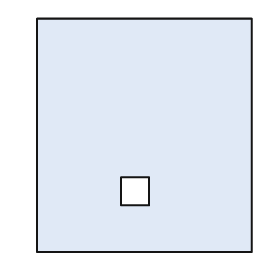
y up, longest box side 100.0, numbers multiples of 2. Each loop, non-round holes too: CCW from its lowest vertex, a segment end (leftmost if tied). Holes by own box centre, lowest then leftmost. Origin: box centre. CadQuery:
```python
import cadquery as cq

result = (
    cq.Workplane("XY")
    .moveTo(-46.0, -50.0)
    .lineTo(46.0, -50.0)
    .lineTo(46.0, 50.0)
    .lineTo(-46.0, 50.0)
    .close()
    .moveTo(-10.0, -30.0)
    .lineTo(2.0, -30.0)
    .lineTo(2.0, -18.0)
    .lineTo(-10.0, -18.0)
    .close()
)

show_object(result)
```